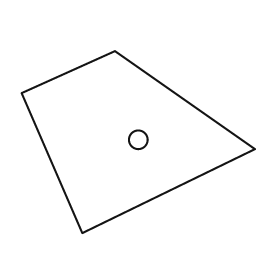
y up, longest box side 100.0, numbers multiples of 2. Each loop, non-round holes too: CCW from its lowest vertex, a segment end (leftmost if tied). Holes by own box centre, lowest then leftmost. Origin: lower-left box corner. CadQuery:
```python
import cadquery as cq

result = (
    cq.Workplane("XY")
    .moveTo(26.0, 0.0)
    .lineTo(100.0, 36.0)
    .lineTo(40.0, 78.0)
    .lineTo(0.0, 60.0)
    .close()
    .moveTo(50.0, 40.0)
    .circle(4.0)
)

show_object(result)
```